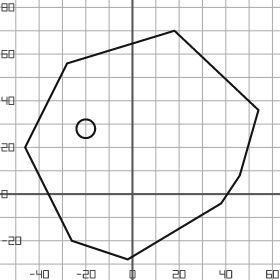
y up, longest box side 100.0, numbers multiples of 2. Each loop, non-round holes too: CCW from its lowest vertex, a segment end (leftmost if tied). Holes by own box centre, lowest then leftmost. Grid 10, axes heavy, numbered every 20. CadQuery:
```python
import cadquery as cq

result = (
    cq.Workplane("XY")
    .moveTo(-2.0, -28.0)
    .lineTo(38.0, -4.0)
    .lineTo(46.0, 8.0)
    .lineTo(54.0, 36.0)
    .lineTo(18.0, 70.0)
    .lineTo(-28.0, 56.0)
    .lineTo(-46.0, 20.0)
    .lineTo(-26.0, -20.0)
    .close()
    .moveTo(-20.0, 28.0)
    .circle(4.0)
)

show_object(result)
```